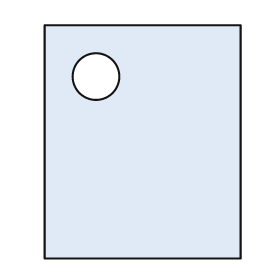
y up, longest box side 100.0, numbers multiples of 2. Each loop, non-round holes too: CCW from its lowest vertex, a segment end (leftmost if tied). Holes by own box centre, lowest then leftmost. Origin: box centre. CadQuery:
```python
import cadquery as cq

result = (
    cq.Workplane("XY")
    .moveTo(-42.0, -50.0)
    .lineTo(42.0, -50.0)
    .lineTo(42.0, 50.0)
    .lineTo(-42.0, 50.0)
    .close()
    .moveTo(-20.0, 28.0)
    .circle(10.0)
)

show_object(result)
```